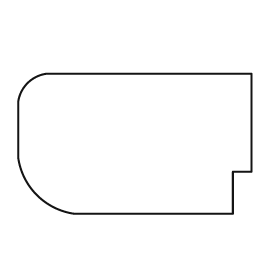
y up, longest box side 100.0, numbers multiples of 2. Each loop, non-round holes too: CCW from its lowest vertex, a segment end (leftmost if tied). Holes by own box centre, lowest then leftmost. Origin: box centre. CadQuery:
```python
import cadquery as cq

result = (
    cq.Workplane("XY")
    .moveTo(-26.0, -30.0)
    .lineTo(42.0, -30.0)
    .lineTo(42.0, -12.0)
    .lineTo(50.0, -12.0)
    .lineTo(50.0, 30.0)
    .lineTo(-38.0, 30.0)
    .threePointArc((-46.0, 26.0), (-50.0, 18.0))
    .lineTo(-50.0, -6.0)
    .threePointArc((-42.0, -22.0), (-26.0, -30.0))
    .close()
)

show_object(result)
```